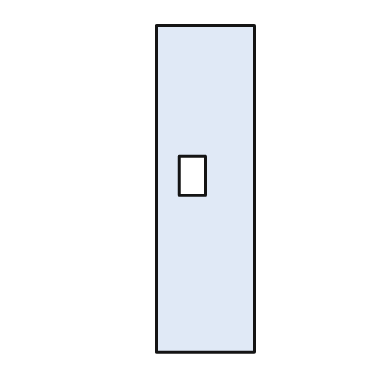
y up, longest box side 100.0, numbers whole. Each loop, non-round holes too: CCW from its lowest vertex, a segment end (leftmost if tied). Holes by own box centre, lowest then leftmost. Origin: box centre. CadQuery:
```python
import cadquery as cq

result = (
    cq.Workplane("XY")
    .moveTo(-15.0, -50.0)
    .lineTo(15.0, -50.0)
    .lineTo(15.0, 50.0)
    .lineTo(-15.0, 50.0)
    .close()
    .moveTo(-8.0, -2.0)
    .lineTo(0.0, -2.0)
    .lineTo(0.0, 10.0)
    .lineTo(-8.0, 10.0)
    .close()
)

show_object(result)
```